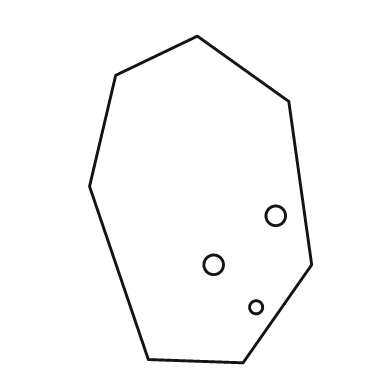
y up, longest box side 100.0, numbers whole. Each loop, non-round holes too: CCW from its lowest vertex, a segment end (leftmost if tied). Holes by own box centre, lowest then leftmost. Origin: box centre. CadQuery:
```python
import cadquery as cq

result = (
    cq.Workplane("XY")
    .moveTo(13.0, -50.0)
    .lineTo(34.0, -20.0)
    .lineTo(27.0, 30.0)
    .lineTo(-1.0, 50.0)
    .lineTo(-26.0, 38.0)
    .lineTo(-34.0, 4.0)
    .lineTo(-16.0, -49.0)
    .close()
    .moveTo(17.0, -33.0)
    .circle(2.0)
    .moveTo(4.0, -20.0)
    .circle(3.0)
    .moveTo(23.0, -5.0)
    .circle(3.0)
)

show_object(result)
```